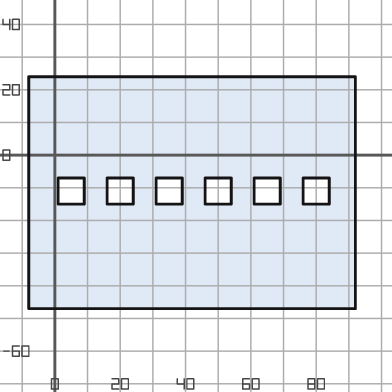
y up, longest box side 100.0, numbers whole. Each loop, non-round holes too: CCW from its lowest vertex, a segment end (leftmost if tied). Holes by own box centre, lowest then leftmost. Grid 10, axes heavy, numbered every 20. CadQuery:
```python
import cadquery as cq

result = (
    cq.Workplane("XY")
    .moveTo(-8.0, -47.0)
    .lineTo(92.0, -47.0)
    .lineTo(92.0, 24.0)
    .lineTo(-8.0, 24.0)
    .close()
    .moveTo(1.0, -15.0)
    .lineTo(9.0, -15.0)
    .lineTo(9.0, -7.0)
    .lineTo(1.0, -7.0)
    .close()
    .moveTo(16.0, -15.0)
    .lineTo(24.0, -15.0)
    .lineTo(24.0, -7.0)
    .lineTo(16.0, -7.0)
    .close()
    .moveTo(31.0, -15.0)
    .lineTo(39.0, -15.0)
    .lineTo(39.0, -7.0)
    .lineTo(31.0, -7.0)
    .close()
    .moveTo(46.0, -15.0)
    .lineTo(54.0, -15.0)
    .lineTo(54.0, -7.0)
    .lineTo(46.0, -7.0)
    .close()
    .moveTo(61.0, -15.0)
    .lineTo(69.0, -15.0)
    .lineTo(69.0, -7.0)
    .lineTo(61.0, -7.0)
    .close()
    .moveTo(76.0, -15.0)
    .lineTo(84.0, -15.0)
    .lineTo(84.0, -7.0)
    .lineTo(76.0, -7.0)
    .close()
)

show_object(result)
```